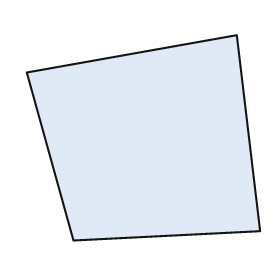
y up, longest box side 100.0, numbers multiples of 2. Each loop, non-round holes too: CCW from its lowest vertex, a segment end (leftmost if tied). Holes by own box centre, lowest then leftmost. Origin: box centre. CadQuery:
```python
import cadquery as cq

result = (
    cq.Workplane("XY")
    .moveTo(-30.0, -44.0)
    .lineTo(50.0, -40.0)
    .lineTo(40.0, 44.0)
    .lineTo(-50.0, 28.0)
    .close()
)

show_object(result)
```